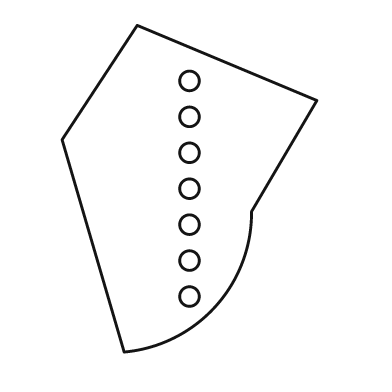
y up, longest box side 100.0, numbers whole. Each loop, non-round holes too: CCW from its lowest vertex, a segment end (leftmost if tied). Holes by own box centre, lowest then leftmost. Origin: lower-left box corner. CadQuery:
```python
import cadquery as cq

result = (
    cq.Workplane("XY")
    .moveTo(19.0, 0.0)
    .threePointArc((47.0, 14.0), (58.0, 43.0))
    .lineTo(78.0, 77.0)
    .lineTo(23.0, 100.0)
    .lineTo(0.0, 65.0)
    .close()
    .moveTo(39.0, 17.0)
    .circle(3.0)
    .moveTo(39.0, 28.0)
    .circle(3.0)
    .moveTo(39.0, 39.0)
    .circle(3.0)
    .moveTo(39.0, 50.0)
    .circle(3.0)
    .moveTo(39.0, 61.0)
    .circle(3.0)
    .moveTo(39.0, 72.0)
    .circle(3.0)
    .moveTo(39.0, 83.0)
    .circle(3.0)
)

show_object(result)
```